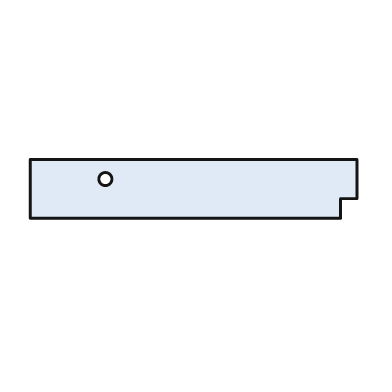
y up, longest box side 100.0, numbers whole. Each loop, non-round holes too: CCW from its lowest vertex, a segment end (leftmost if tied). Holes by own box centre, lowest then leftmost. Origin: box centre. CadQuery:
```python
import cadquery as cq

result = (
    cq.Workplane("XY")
    .moveTo(-50.0, -9.0)
    .lineTo(45.0, -9.0)
    .lineTo(45.0, -3.0)
    .lineTo(50.0, -3.0)
    .lineTo(50.0, 9.0)
    .lineTo(-50.0, 9.0)
    .close()
    .moveTo(-27.0, 3.0)
    .circle(2.0)
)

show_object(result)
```